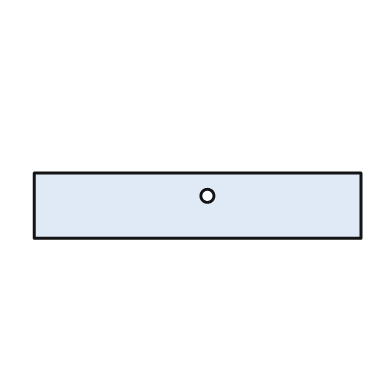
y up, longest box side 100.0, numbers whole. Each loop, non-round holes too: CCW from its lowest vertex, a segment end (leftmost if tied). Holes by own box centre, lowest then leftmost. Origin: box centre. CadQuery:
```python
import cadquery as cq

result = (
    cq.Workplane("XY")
    .moveTo(-50.0, -10.0)
    .lineTo(50.0, -10.0)
    .lineTo(50.0, 10.0)
    .lineTo(-50.0, 10.0)
    .close()
    .moveTo(3.0, 3.0)
    .circle(2.0)
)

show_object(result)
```